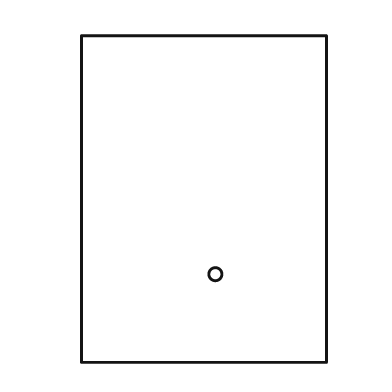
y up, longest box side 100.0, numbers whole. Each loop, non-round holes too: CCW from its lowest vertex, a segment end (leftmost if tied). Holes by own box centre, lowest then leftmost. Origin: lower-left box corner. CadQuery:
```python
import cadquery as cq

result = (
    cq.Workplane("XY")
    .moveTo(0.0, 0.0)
    .lineTo(75.0, 0.0)
    .lineTo(75.0, 100.0)
    .lineTo(0.0, 100.0)
    .close()
    .moveTo(41.0, 27.0)
    .circle(2.0)
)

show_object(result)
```